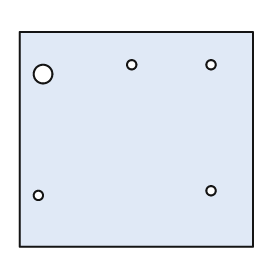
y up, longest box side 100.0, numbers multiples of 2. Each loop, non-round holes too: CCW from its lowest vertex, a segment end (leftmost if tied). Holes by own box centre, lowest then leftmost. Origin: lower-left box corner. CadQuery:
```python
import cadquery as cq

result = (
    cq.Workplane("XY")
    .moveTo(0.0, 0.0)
    .lineTo(100.0, 0.0)
    .lineTo(100.0, 92.0)
    .lineTo(0.0, 92.0)
    .close()
    .moveTo(8.0, 22.0)
    .circle(2.0)
    .moveTo(82.0, 24.0)
    .circle(2.0)
    .moveTo(10.0, 74.0)
    .circle(4.0)
    .moveTo(48.0, 78.0)
    .circle(2.0)
    .moveTo(82.0, 78.0)
    .circle(2.0)
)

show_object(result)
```